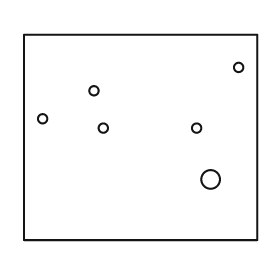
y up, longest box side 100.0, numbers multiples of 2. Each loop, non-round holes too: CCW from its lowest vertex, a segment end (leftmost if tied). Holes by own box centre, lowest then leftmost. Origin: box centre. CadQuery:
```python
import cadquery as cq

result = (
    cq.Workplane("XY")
    .moveTo(-50.0, -44.0)
    .lineTo(50.0, -44.0)
    .lineTo(50.0, 44.0)
    .lineTo(-50.0, 44.0)
    .close()
    .moveTo(30.0, -18.0)
    .circle(4.0)
    .moveTo(-16.0, 4.0)
    .circle(2.0)
    .moveTo(24.0, 4.0)
    .circle(2.0)
    .moveTo(-42.0, 8.0)
    .circle(2.0)
    .moveTo(-20.0, 20.0)
    .circle(2.0)
    .moveTo(42.0, 30.0)
    .circle(2.0)
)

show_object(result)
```